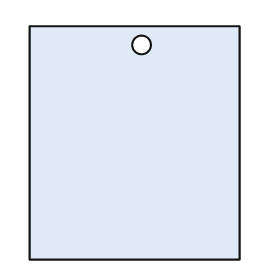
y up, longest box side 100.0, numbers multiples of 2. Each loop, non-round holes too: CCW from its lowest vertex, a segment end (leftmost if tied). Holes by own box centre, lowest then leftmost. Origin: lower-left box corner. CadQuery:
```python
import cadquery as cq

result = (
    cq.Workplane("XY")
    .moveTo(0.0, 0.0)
    .lineTo(90.0, 0.0)
    .lineTo(90.0, 100.0)
    .lineTo(0.0, 100.0)
    .close()
    .moveTo(48.0, 92.0)
    .circle(4.0)
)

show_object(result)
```